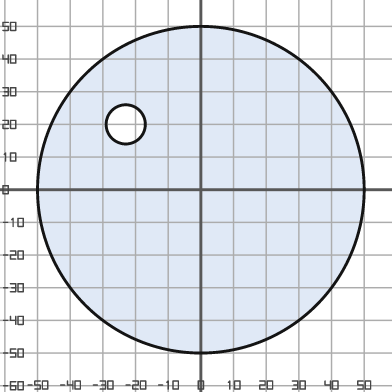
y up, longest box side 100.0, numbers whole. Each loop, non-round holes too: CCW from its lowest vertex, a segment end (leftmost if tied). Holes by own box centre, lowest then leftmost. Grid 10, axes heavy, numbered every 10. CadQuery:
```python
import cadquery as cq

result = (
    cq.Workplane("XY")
    .moveTo(0.0, 0.0)
    .circle(50.0)
    .moveTo(-23.0, 20.0)
    .circle(6.0)
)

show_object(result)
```